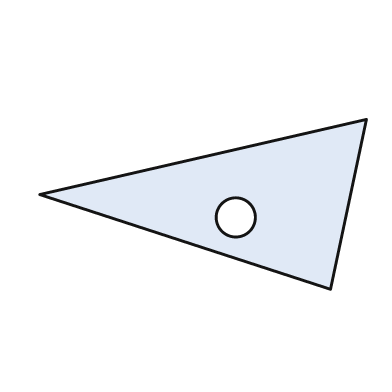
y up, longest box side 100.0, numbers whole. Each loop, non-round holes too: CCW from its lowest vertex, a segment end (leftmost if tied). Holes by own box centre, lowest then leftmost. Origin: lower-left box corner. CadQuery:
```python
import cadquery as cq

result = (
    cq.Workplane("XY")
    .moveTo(89.0, 0.0)
    .lineTo(100.0, 52.0)
    .lineTo(0.0, 29.0)
    .close()
    .moveTo(60.0, 22.0)
    .circle(6.0)
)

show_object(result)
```